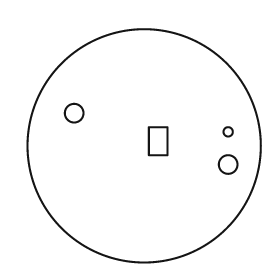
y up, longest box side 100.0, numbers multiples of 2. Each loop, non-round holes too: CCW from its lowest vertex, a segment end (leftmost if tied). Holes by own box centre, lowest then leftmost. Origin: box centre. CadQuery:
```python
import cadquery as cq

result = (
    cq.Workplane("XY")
    .moveTo(0.0, 0.0)
    .circle(50.0)
    .moveTo(36.0, -8.0)
    .circle(4.0)
    .moveTo(2.0, -4.0)
    .lineTo(10.0, -4.0)
    .lineTo(10.0, 8.0)
    .lineTo(2.0, 8.0)
    .close()
    .moveTo(36.0, 6.0)
    .circle(2.0)
    .moveTo(-30.0, 14.0)
    .circle(4.0)
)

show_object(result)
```